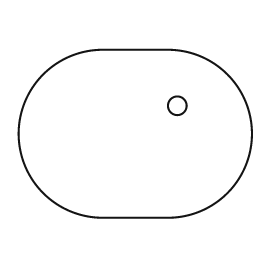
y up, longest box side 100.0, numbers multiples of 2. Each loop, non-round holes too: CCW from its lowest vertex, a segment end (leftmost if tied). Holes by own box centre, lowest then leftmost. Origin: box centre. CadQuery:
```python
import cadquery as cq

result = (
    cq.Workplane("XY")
    .moveTo(-14.0, -36.0)
    .lineTo(14.0, -36.0)
    .threePointArc((50.0, 0.0), (14.0, 36.0))
    .lineTo(-14.0, 36.0)
    .threePointArc((-50.0, 0.0), (-14.0, -36.0))
    .close()
    .moveTo(18.0, 12.0)
    .circle(4.0)
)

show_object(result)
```